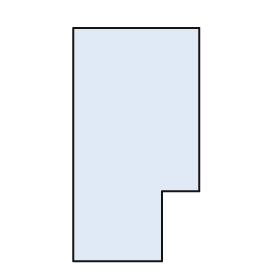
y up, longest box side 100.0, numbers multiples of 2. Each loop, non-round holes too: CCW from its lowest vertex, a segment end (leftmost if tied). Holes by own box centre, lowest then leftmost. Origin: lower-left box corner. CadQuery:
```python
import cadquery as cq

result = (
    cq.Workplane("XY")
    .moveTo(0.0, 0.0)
    .lineTo(38.0, 0.0)
    .lineTo(38.0, 30.0)
    .lineTo(54.0, 30.0)
    .lineTo(54.0, 100.0)
    .lineTo(0.0, 100.0)
    .close()
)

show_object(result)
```